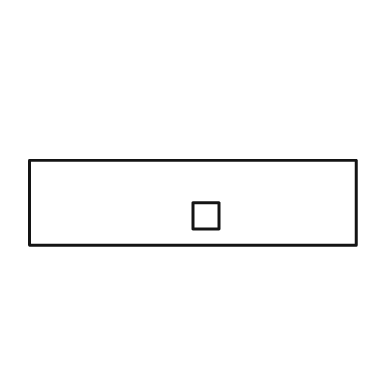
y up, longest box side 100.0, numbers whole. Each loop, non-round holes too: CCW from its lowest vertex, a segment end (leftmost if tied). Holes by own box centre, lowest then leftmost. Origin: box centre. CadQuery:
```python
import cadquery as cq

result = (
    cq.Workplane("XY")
    .moveTo(-50.0, -13.0)
    .lineTo(50.0, -13.0)
    .lineTo(50.0, 13.0)
    .lineTo(-50.0, 13.0)
    .close()
    .moveTo(0.0, -8.0)
    .lineTo(8.0, -8.0)
    .lineTo(8.0, 0.0)
    .lineTo(0.0, 0.0)
    .close()
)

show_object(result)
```